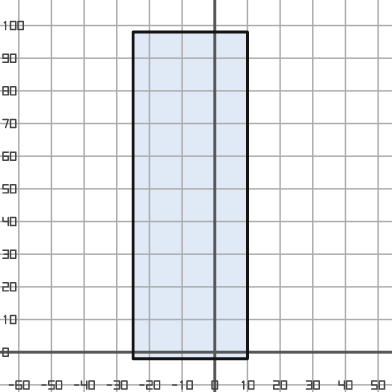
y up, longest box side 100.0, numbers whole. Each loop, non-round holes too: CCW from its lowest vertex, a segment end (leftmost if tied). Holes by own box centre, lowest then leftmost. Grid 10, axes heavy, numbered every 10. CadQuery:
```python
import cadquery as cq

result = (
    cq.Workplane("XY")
    .moveTo(-25.0, -2.0)
    .lineTo(10.0, -2.0)
    .lineTo(10.0, 98.0)
    .lineTo(-25.0, 98.0)
    .close()
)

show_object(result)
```